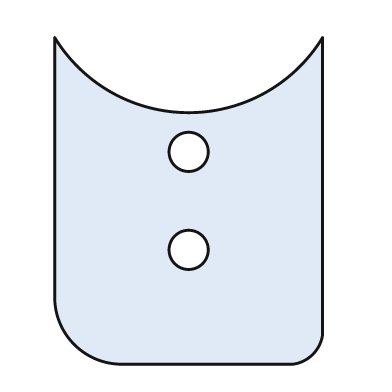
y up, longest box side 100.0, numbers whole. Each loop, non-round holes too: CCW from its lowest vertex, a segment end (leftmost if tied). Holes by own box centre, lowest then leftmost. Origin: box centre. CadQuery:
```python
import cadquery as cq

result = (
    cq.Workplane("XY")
    .moveTo(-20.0, -50.0)
    .lineTo(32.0, -50.0)
    .threePointArc((38.0, -47.0), (41.0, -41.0))
    .lineTo(41.0, 50.0)
    .threePointArc((0.0, 27.0), (-41.0, 50.0))
    .lineTo(-41.0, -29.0)
    .threePointArc((-35.0, -44.0), (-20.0, -50.0))
    .close()
    .moveTo(0.0, -15.0)
    .circle(6.0)
    .moveTo(0.0, 15.0)
    .circle(6.0)
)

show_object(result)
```